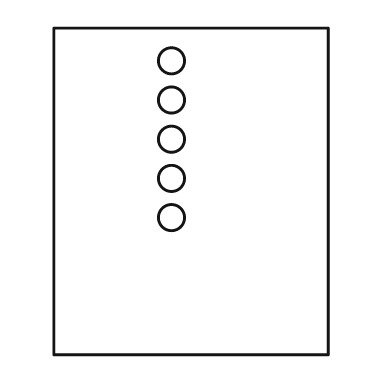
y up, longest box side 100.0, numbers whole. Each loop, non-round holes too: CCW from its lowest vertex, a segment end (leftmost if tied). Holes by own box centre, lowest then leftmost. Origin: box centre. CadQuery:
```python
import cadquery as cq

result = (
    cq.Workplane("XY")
    .moveTo(-42.0, -50.0)
    .lineTo(42.0, -50.0)
    .lineTo(42.0, 50.0)
    .lineTo(-42.0, 50.0)
    .close()
    .moveTo(-6.0, -8.0)
    .circle(4.0)
    .moveTo(-6.0, 4.0)
    .circle(4.0)
    .moveTo(-6.0, 16.0)
    .circle(4.0)
    .moveTo(-6.0, 28.0)
    .circle(4.0)
    .moveTo(-6.0, 40.0)
    .circle(4.0)
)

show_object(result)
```